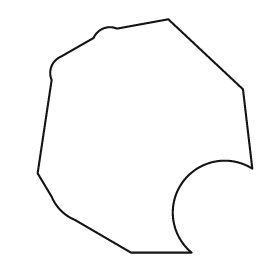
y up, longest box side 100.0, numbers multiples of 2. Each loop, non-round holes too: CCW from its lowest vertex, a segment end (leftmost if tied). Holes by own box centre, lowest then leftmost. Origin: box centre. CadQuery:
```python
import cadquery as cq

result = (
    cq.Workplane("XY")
    .moveTo(-6.0, -50.0)
    .lineTo(20.0, -50.0)
    .threePointArc((16.0, -20.0), (46.0, -14.0))
    .lineTo(42.0, 20.0)
    .lineTo(10.0, 50.0)
    .lineTo(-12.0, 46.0)
    .threePointArc((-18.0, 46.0), (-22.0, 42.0))
    .lineTo(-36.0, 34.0)
    .threePointArc((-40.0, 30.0), (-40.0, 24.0))
    .lineTo(-46.0, -16.0)
    .lineTo(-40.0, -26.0)
    .threePointArc((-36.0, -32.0), (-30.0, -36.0))
    .close()
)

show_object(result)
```